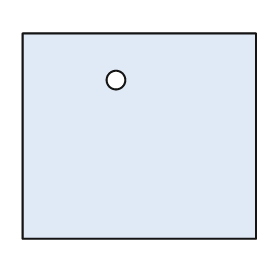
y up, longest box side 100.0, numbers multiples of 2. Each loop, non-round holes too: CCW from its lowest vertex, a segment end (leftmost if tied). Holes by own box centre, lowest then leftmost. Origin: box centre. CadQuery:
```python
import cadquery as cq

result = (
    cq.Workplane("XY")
    .moveTo(-50.0, -44.0)
    .lineTo(50.0, -44.0)
    .lineTo(50.0, 44.0)
    .lineTo(-50.0, 44.0)
    .close()
    .moveTo(-10.0, 24.0)
    .circle(4.0)
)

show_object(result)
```